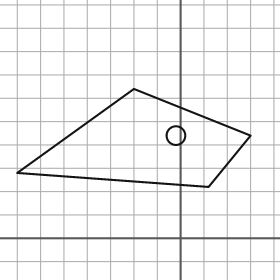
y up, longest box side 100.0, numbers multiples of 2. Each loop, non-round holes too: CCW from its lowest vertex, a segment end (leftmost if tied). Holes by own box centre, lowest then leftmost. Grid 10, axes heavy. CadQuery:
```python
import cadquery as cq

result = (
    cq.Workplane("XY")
    .moveTo(12.0, 22.0)
    .lineTo(30.0, 44.0)
    .lineTo(-20.0, 64.0)
    .lineTo(-70.0, 28.0)
    .close()
    .moveTo(-2.0, 44.0)
    .circle(4.0)
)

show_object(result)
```